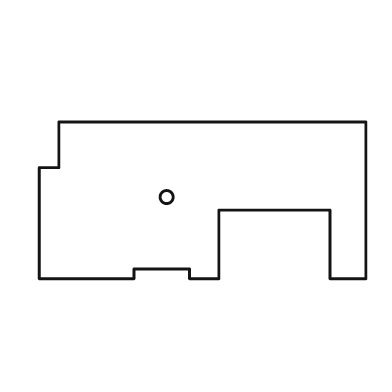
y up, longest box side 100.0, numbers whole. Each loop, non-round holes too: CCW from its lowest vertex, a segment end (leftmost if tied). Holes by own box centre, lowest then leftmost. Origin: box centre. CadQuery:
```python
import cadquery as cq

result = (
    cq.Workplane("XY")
    .moveTo(-50.0, -24.0)
    .lineTo(-21.0, -24.0)
    .lineTo(-21.0, -21.0)
    .lineTo(-4.0, -21.0)
    .lineTo(-4.0, -24.0)
    .lineTo(5.0, -24.0)
    .lineTo(5.0, -3.0)
    .lineTo(39.0, -3.0)
    .lineTo(39.0, -24.0)
    .lineTo(50.0, -24.0)
    .lineTo(50.0, 24.0)
    .lineTo(-44.0, 24.0)
    .lineTo(-44.0, 10.0)
    .lineTo(-50.0, 10.0)
    .close()
    .moveTo(-11.0, 1.0)
    .circle(2.0)
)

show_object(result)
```